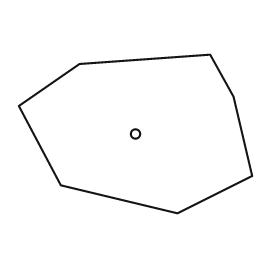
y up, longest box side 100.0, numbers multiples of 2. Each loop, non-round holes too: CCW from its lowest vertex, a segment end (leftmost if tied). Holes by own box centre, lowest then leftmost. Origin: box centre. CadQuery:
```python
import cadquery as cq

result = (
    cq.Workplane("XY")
    .moveTo(18.0, -34.0)
    .lineTo(50.0, -18.0)
    .lineTo(42.0, 16.0)
    .lineTo(32.0, 34.0)
    .lineTo(-24.0, 30.0)
    .lineTo(-50.0, 12.0)
    .lineTo(-32.0, -22.0)
    .close()
    .moveTo(0.0, 0.0)
    .circle(2.0)
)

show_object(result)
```